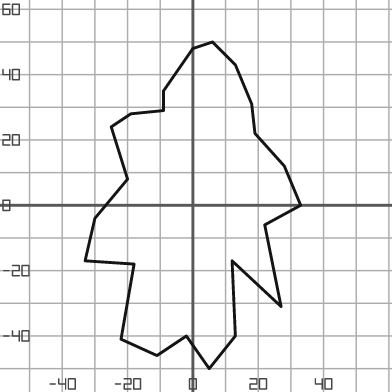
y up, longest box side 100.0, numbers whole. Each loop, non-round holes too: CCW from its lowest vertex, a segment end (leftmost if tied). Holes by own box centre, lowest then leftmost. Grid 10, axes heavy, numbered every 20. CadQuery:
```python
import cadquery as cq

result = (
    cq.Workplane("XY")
    .moveTo(5.0, -50.0)
    .lineTo(13.0, -40.0)
    .lineTo(12.0, -17.0)
    .lineTo(27.0, -31.0)
    .lineTo(22.0, -6.0)
    .lineTo(33.0, 0.0)
    .lineTo(28.0, 12.0)
    .lineTo(19.0, 22.0)
    .lineTo(18.0, 31.0)
    .lineTo(13.0, 43.0)
    .lineTo(6.0, 50.0)
    .lineTo(0.0, 48.0)
    .lineTo(-9.0, 35.0)
    .lineTo(-9.0, 29.0)
    .lineTo(-19.0, 28.0)
    .lineTo(-25.0, 24.0)
    .lineTo(-20.0, 8.0)
    .lineTo(-30.0, -4.0)
    .lineTo(-33.0, -17.0)
    .lineTo(-18.0, -18.0)
    .lineTo(-22.0, -41.0)
    .lineTo(-11.0, -46.0)
    .lineTo(-2.0, -40.0)
    .close()
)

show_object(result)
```